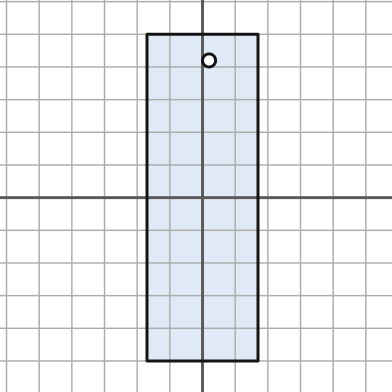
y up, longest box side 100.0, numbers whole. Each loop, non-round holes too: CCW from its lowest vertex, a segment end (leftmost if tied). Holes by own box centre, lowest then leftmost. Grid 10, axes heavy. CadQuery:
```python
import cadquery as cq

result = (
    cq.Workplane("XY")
    .moveTo(-17.0, -50.0)
    .lineTo(17.0, -50.0)
    .lineTo(17.0, 50.0)
    .lineTo(-17.0, 50.0)
    .close()
    .moveTo(2.0, 42.0)
    .circle(2.0)
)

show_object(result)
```